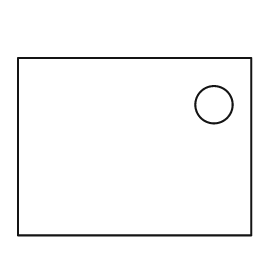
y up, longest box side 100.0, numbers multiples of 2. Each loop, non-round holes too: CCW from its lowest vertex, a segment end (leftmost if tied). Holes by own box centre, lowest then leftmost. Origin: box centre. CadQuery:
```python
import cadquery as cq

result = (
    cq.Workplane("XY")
    .moveTo(-50.0, -38.0)
    .lineTo(50.0, -38.0)
    .lineTo(50.0, 38.0)
    .lineTo(-50.0, 38.0)
    .close()
    .moveTo(34.0, 18.0)
    .circle(8.0)
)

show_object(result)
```